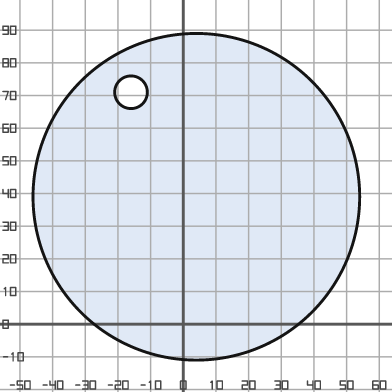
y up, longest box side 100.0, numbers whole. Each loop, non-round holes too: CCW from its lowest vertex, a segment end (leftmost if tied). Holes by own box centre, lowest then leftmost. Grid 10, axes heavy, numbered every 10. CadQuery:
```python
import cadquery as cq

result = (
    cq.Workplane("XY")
    .moveTo(4.0, 39.0)
    .circle(50.0)
    .moveTo(-16.0, 71.0)
    .circle(5.0)
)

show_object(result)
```